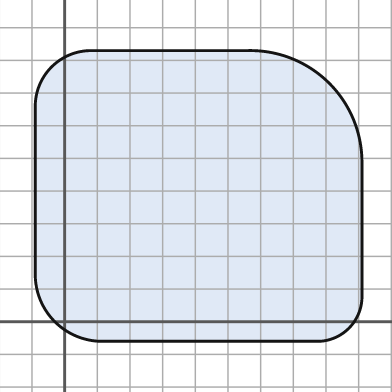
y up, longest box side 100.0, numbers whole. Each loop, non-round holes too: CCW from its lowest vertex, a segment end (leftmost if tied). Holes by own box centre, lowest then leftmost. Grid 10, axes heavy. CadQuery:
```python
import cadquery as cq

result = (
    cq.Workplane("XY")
    .moveTo(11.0, -6.0)
    .lineTo(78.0, -6.0)
    .threePointArc((87.0, -2.0), (91.0, 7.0))
    .lineTo(91.0, 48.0)
    .threePointArc((81.0, 73.0), (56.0, 83.0))
    .lineTo(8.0, 83.0)
    .threePointArc((-4.0, 78.0), (-9.0, 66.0))
    .lineTo(-9.0, 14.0)
    .threePointArc((-3.0, 0.0), (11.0, -6.0))
    .close()
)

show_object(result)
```